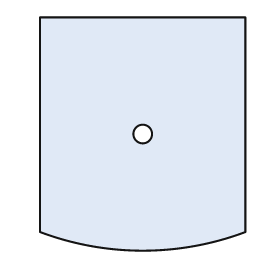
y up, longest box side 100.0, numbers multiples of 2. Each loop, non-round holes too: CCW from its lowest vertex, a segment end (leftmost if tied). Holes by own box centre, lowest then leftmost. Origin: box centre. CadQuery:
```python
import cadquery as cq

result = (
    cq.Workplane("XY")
    .moveTo(-44.0, -42.0)
    .threePointArc((0.0, -50.0), (44.0, -42.0))
    .lineTo(44.0, 50.0)
    .lineTo(-44.0, 50.0)
    .close()
    .moveTo(0.0, 0.0)
    .circle(4.0)
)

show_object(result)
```